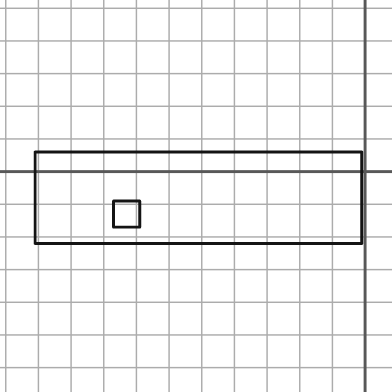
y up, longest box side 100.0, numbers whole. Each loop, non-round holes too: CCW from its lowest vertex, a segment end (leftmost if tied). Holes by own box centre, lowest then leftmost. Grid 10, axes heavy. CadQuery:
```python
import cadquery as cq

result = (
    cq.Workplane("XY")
    .moveTo(-101.0, -22.0)
    .lineTo(-1.0, -22.0)
    .lineTo(-1.0, 6.0)
    .lineTo(-101.0, 6.0)
    .close()
    .moveTo(-77.0, -17.0)
    .lineTo(-69.0, -17.0)
    .lineTo(-69.0, -9.0)
    .lineTo(-77.0, -9.0)
    .close()
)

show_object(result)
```